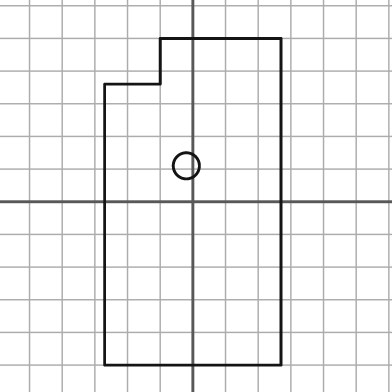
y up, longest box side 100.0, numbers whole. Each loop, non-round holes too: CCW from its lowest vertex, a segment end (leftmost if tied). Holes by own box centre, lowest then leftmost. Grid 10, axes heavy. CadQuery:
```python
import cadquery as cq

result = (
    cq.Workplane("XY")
    .moveTo(-27.0, -50.0)
    .lineTo(27.0, -50.0)
    .lineTo(27.0, 50.0)
    .lineTo(-10.0, 50.0)
    .lineTo(-10.0, 36.0)
    .lineTo(-27.0, 36.0)
    .close()
    .moveTo(-2.0, 11.0)
    .circle(4.0)
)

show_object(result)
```